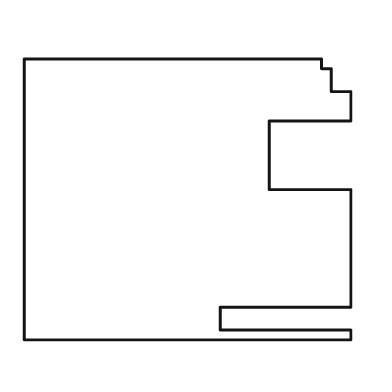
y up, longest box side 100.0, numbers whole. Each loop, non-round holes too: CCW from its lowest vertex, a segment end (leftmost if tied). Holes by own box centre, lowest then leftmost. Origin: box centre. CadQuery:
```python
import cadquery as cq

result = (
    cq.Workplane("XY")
    .moveTo(-50.0, -43.0)
    .lineTo(50.0, -43.0)
    .lineTo(50.0, -40.0)
    .lineTo(10.0, -40.0)
    .lineTo(10.0, -33.0)
    .lineTo(50.0, -33.0)
    .lineTo(50.0, 3.0)
    .lineTo(25.0, 3.0)
    .lineTo(25.0, 24.0)
    .lineTo(50.0, 24.0)
    .lineTo(50.0, 33.0)
    .lineTo(44.0, 33.0)
    .lineTo(44.0, 40.0)
    .lineTo(41.0, 40.0)
    .lineTo(41.0, 43.0)
    .lineTo(-50.0, 43.0)
    .close()
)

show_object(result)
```